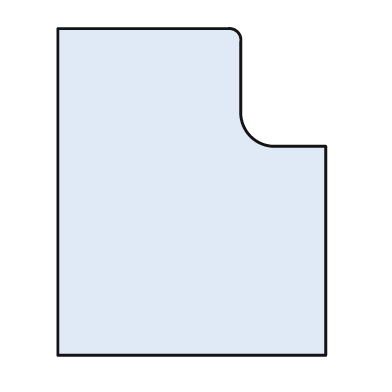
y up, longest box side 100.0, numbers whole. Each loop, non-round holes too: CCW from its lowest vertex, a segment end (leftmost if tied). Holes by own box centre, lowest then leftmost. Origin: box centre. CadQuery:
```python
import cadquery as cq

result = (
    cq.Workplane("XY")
    .moveTo(-41.0, -50.0)
    .lineTo(41.0, -50.0)
    .lineTo(41.0, 14.0)
    .lineTo(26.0, 14.0)
    .threePointArc((18.0, 17.0), (15.0, 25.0))
    .lineTo(15.0, 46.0)
    .threePointArc((14.0, 49.0), (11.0, 50.0))
    .lineTo(-41.0, 50.0)
    .close()
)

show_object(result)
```